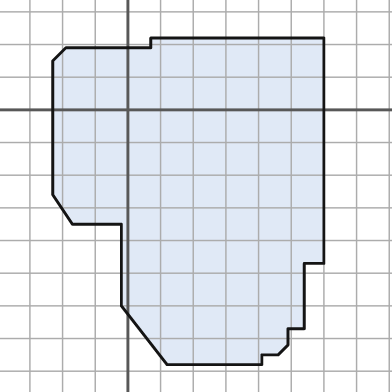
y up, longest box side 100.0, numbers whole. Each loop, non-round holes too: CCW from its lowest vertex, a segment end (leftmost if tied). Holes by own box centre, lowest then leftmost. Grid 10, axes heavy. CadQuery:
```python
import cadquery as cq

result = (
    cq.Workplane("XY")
    .moveTo(12.0, -78.0)
    .lineTo(41.0, -78.0)
    .lineTo(41.0, -75.0)
    .lineTo(46.0, -75.0)
    .lineTo(49.0, -72.0)
    .lineTo(49.0, -67.0)
    .lineTo(54.0, -67.0)
    .lineTo(54.0, -47.0)
    .lineTo(60.0, -47.0)
    .lineTo(60.0, 22.0)
    .lineTo(7.0, 22.0)
    .lineTo(7.0, 19.0)
    .lineTo(-19.0, 19.0)
    .lineTo(-23.0, 15.0)
    .lineTo(-23.0, -26.0)
    .lineTo(-17.0, -35.0)
    .lineTo(-2.0, -35.0)
    .lineTo(-2.0, -60.0)
    .close()
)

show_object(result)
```